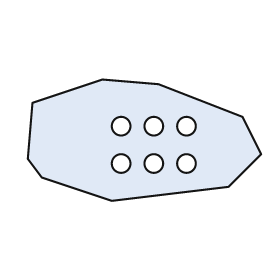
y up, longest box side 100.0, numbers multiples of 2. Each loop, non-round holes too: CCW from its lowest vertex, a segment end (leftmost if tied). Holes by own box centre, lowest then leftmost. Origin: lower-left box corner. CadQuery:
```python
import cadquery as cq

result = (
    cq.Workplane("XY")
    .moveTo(36.0, 0.0)
    .lineTo(86.0, 6.0)
    .lineTo(100.0, 20.0)
    .lineTo(92.0, 36.0)
    .lineTo(56.0, 50.0)
    .lineTo(32.0, 52.0)
    .lineTo(2.0, 42.0)
    .lineTo(0.0, 18.0)
    .lineTo(6.0, 10.0)
    .close()
    .moveTo(40.0, 16.0)
    .circle(4.0)
    .moveTo(54.0, 16.0)
    .circle(4.0)
    .moveTo(68.0, 16.0)
    .circle(4.0)
    .moveTo(40.0, 32.0)
    .circle(4.0)
    .moveTo(54.0, 32.0)
    .circle(4.0)
    .moveTo(68.0, 32.0)
    .circle(4.0)
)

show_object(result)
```